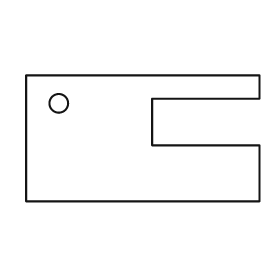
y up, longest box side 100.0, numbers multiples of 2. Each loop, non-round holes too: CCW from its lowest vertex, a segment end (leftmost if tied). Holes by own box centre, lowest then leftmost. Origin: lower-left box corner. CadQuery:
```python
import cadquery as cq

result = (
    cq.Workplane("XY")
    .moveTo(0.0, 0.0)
    .lineTo(100.0, 0.0)
    .lineTo(100.0, 24.0)
    .lineTo(54.0, 24.0)
    .lineTo(54.0, 44.0)
    .lineTo(100.0, 44.0)
    .lineTo(100.0, 54.0)
    .lineTo(0.0, 54.0)
    .close()
    .moveTo(14.0, 42.0)
    .circle(4.0)
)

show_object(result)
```